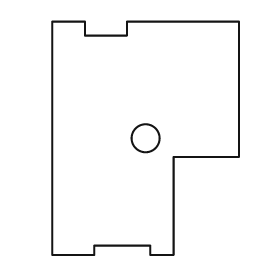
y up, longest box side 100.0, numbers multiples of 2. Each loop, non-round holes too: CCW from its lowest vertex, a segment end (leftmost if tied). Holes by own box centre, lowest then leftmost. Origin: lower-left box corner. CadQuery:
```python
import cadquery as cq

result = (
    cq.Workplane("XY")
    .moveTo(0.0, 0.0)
    .lineTo(18.0, 0.0)
    .lineTo(18.0, 4.0)
    .lineTo(42.0, 4.0)
    .lineTo(42.0, 0.0)
    .lineTo(52.0, 0.0)
    .lineTo(52.0, 42.0)
    .lineTo(80.0, 42.0)
    .lineTo(80.0, 100.0)
    .lineTo(32.0, 100.0)
    .lineTo(32.0, 94.0)
    .lineTo(14.0, 94.0)
    .lineTo(14.0, 100.0)
    .lineTo(0.0, 100.0)
    .close()
    .moveTo(40.0, 50.0)
    .circle(6.0)
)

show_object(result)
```